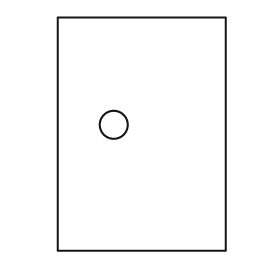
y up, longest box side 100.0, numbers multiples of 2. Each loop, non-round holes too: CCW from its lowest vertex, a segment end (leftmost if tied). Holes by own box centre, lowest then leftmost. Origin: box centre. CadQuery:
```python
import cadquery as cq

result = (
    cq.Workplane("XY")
    .moveTo(-36.0, -50.0)
    .lineTo(36.0, -50.0)
    .lineTo(36.0, 50.0)
    .lineTo(-36.0, 50.0)
    .close()
    .moveTo(-12.0, 4.0)
    .circle(6.0)
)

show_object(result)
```